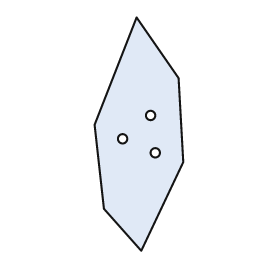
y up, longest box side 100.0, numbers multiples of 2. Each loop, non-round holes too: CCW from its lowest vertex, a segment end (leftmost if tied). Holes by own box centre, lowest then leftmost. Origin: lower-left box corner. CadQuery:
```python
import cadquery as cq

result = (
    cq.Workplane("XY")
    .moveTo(20.0, 0.0)
    .lineTo(38.0, 38.0)
    .lineTo(36.0, 74.0)
    .lineTo(18.0, 100.0)
    .lineTo(0.0, 54.0)
    .lineTo(4.0, 18.0)
    .close()
    .moveTo(26.0, 42.0)
    .circle(2.0)
    .moveTo(12.0, 48.0)
    .circle(2.0)
    .moveTo(24.0, 58.0)
    .circle(2.0)
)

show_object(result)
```